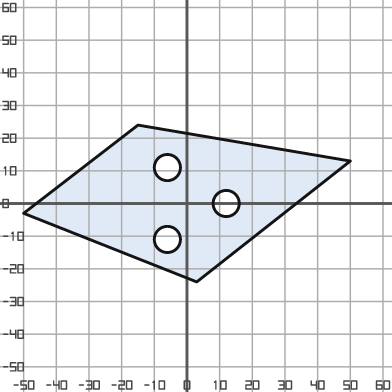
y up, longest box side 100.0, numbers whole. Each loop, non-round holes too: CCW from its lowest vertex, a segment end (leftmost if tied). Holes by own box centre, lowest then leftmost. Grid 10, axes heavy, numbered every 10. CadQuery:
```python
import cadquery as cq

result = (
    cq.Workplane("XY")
    .moveTo(3.0, -24.0)
    .lineTo(50.0, 13.0)
    .lineTo(-15.0, 24.0)
    .lineTo(-50.0, -3.0)
    .close()
    .moveTo(-6.0, -11.0)
    .circle(4.0)
    .moveTo(12.0, 0.0)
    .circle(4.0)
    .moveTo(-6.0, 11.0)
    .circle(4.0)
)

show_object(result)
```